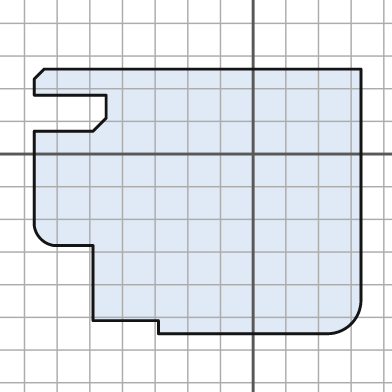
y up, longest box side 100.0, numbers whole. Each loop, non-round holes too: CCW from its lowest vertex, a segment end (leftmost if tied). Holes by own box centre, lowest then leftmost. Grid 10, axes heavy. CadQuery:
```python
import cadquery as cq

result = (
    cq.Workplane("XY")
    .moveTo(-29.0, -55.0)
    .lineTo(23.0, -55.0)
    .threePointArc((30.0, -52.0), (33.0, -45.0))
    .lineTo(33.0, 26.0)
    .lineTo(-64.0, 26.0)
    .lineTo(-67.0, 23.0)
    .lineTo(-67.0, 18.0)
    .lineTo(-45.0, 18.0)
    .lineTo(-45.0, 11.0)
    .lineTo(-49.0, 7.0)
    .lineTo(-67.0, 7.0)
    .lineTo(-67.0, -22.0)
    .threePointArc((-65.0, -26.0), (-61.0, -28.0))
    .lineTo(-49.0, -28.0)
    .lineTo(-49.0, -51.0)
    .lineTo(-29.0, -51.0)
    .close()
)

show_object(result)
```